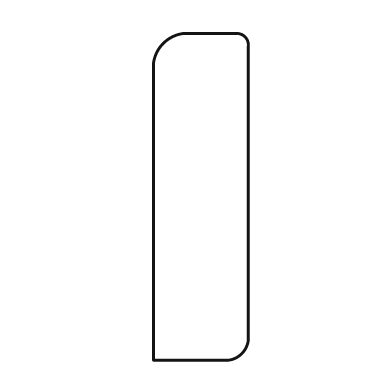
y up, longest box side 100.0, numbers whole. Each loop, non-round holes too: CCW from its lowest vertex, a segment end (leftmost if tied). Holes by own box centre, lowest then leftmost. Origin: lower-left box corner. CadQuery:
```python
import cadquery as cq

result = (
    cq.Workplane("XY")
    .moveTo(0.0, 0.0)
    .lineTo(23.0, 0.0)
    .threePointArc((27.0, 2.0), (29.0, 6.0))
    .lineTo(29.0, 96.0)
    .threePointArc((28.0, 99.0), (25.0, 100.0))
    .lineTo(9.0, 100.0)
    .threePointArc((3.0, 97.0), (0.0, 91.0))
    .close()
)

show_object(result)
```